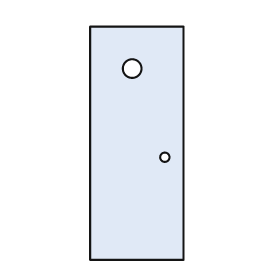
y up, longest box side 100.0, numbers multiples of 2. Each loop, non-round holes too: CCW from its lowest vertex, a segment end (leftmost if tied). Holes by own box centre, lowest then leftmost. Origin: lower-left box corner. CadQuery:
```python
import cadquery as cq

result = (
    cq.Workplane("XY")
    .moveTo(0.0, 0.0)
    .lineTo(40.0, 0.0)
    .lineTo(40.0, 100.0)
    .lineTo(0.0, 100.0)
    .close()
    .moveTo(32.0, 44.0)
    .circle(2.0)
    .moveTo(18.0, 82.0)
    .circle(4.0)
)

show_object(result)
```